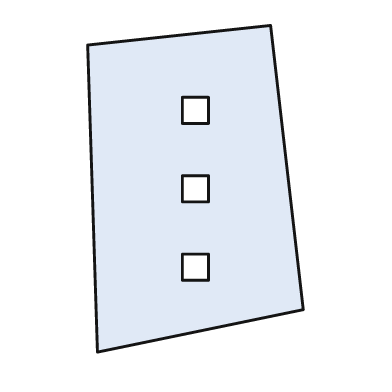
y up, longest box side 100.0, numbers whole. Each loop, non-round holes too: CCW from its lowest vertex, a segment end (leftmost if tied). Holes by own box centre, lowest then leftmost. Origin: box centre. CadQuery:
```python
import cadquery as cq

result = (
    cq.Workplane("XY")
    .moveTo(-30.0, -50.0)
    .lineTo(33.0, -37.0)
    .lineTo(23.0, 50.0)
    .lineTo(-33.0, 44.0)
    .close()
    .moveTo(-4.0, -28.0)
    .lineTo(4.0, -28.0)
    .lineTo(4.0, -20.0)
    .lineTo(-4.0, -20.0)
    .close()
    .moveTo(-4.0, -4.0)
    .lineTo(4.0, -4.0)
    .lineTo(4.0, 4.0)
    .lineTo(-4.0, 4.0)
    .close()
    .moveTo(-4.0, 20.0)
    .lineTo(4.0, 20.0)
    .lineTo(4.0, 28.0)
    .lineTo(-4.0, 28.0)
    .close()
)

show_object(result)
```